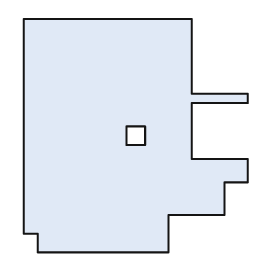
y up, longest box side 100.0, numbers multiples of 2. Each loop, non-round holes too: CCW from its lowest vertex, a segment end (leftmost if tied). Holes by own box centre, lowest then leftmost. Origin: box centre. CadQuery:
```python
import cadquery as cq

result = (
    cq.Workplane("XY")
    .moveTo(-42.0, -50.0)
    .lineTo(14.0, -50.0)
    .lineTo(14.0, -34.0)
    .lineTo(38.0, -34.0)
    .lineTo(38.0, -20.0)
    .lineTo(48.0, -20.0)
    .lineTo(48.0, -10.0)
    .lineTo(24.0, -10.0)
    .lineTo(24.0, 14.0)
    .lineTo(48.0, 14.0)
    .lineTo(48.0, 18.0)
    .lineTo(24.0, 18.0)
    .lineTo(24.0, 50.0)
    .lineTo(-48.0, 50.0)
    .lineTo(-48.0, -42.0)
    .lineTo(-42.0, -42.0)
    .close()
    .moveTo(-4.0, -4.0)
    .lineTo(4.0, -4.0)
    .lineTo(4.0, 4.0)
    .lineTo(-4.0, 4.0)
    .close()
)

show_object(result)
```